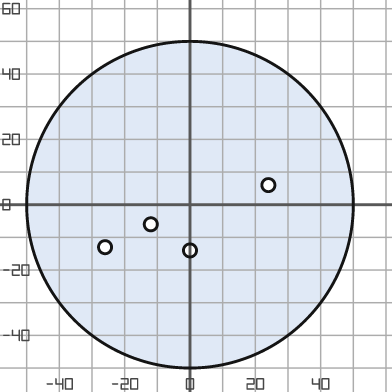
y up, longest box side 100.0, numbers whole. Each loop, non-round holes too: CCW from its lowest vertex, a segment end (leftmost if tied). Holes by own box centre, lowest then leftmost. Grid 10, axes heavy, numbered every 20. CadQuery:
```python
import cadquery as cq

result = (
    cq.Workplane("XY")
    .moveTo(0.0, 0.0)
    .circle(50.0)
    .moveTo(0.0, -14.0)
    .circle(2.0)
    .moveTo(-26.0, -13.0)
    .circle(2.0)
    .moveTo(-12.0, -6.0)
    .circle(2.0)
    .moveTo(24.0, 6.0)
    .circle(2.0)
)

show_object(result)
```